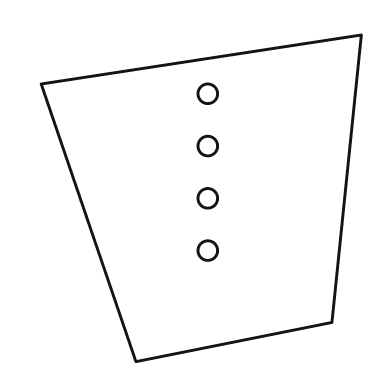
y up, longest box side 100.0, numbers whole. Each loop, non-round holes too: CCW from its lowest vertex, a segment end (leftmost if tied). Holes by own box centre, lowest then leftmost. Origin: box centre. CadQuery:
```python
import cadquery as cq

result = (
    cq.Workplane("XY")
    .moveTo(-20.0, -50.0)
    .lineTo(40.0, -38.0)
    .lineTo(49.0, 50.0)
    .lineTo(-49.0, 35.0)
    .close()
    .moveTo(2.0, -16.0)
    .circle(3.0)
    .moveTo(2.0, 0.0)
    .circle(3.0)
    .moveTo(2.0, 16.0)
    .circle(3.0)
    .moveTo(2.0, 32.0)
    .circle(3.0)
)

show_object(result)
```